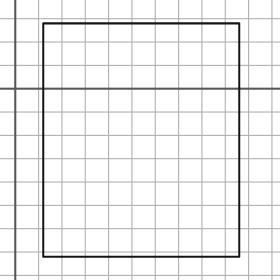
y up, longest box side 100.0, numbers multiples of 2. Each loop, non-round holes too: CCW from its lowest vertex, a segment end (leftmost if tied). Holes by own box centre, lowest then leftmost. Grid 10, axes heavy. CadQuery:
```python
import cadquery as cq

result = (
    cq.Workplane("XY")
    .moveTo(12.0, -72.0)
    .lineTo(96.0, -72.0)
    .lineTo(96.0, 28.0)
    .lineTo(12.0, 28.0)
    .close()
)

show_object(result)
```